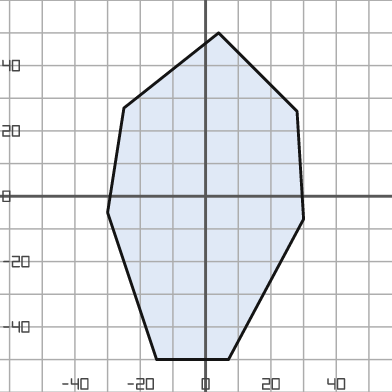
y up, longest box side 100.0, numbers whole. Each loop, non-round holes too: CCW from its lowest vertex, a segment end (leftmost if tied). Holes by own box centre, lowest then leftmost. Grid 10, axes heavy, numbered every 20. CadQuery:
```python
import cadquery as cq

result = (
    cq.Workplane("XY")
    .moveTo(-15.0, -50.0)
    .lineTo(7.0, -50.0)
    .lineTo(30.0, -7.0)
    .lineTo(28.0, 26.0)
    .lineTo(4.0, 50.0)
    .lineTo(-25.0, 27.0)
    .lineTo(-30.0, -5.0)
    .close()
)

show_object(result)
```